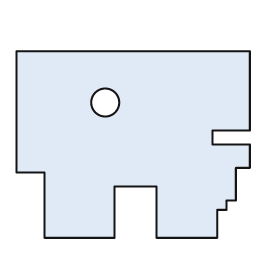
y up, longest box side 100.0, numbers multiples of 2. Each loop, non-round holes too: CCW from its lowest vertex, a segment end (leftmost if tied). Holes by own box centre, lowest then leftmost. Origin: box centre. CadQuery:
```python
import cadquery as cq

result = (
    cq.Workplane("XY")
    .moveTo(-38.0, -40.0)
    .lineTo(-8.0, -40.0)
    .lineTo(-8.0, -18.0)
    .lineTo(10.0, -18.0)
    .lineTo(10.0, -40.0)
    .lineTo(36.0, -40.0)
    .lineTo(36.0, -28.0)
    .lineTo(40.0, -28.0)
    .lineTo(40.0, -24.0)
    .lineTo(44.0, -24.0)
    .lineTo(44.0, -10.0)
    .lineTo(50.0, -10.0)
    .lineTo(50.0, 0.0)
    .lineTo(34.0, 0.0)
    .lineTo(34.0, 6.0)
    .lineTo(50.0, 6.0)
    .lineTo(50.0, 40.0)
    .lineTo(-50.0, 40.0)
    .lineTo(-50.0, -12.0)
    .lineTo(-38.0, -12.0)
    .close()
    .moveTo(-12.0, 18.0)
    .circle(6.0)
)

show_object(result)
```